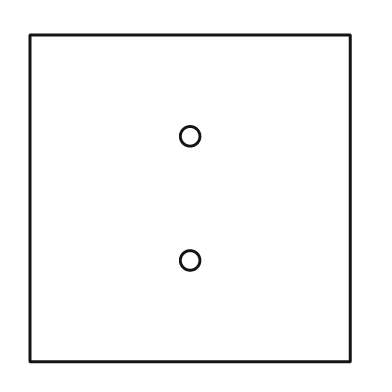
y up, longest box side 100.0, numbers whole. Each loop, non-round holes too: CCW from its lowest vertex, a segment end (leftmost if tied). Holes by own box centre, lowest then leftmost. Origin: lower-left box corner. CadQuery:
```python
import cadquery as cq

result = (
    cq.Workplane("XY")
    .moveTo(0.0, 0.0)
    .lineTo(98.0, 0.0)
    .lineTo(98.0, 100.0)
    .lineTo(0.0, 100.0)
    .close()
    .moveTo(49.0, 31.0)
    .circle(3.0)
    .moveTo(49.0, 69.0)
    .circle(3.0)
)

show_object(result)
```